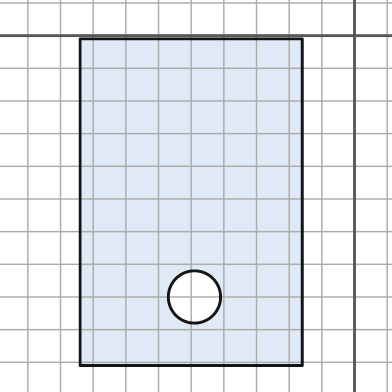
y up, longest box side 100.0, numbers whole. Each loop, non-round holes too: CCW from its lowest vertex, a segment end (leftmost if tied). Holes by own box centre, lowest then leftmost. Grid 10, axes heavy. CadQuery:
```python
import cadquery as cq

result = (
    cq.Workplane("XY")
    .moveTo(-84.0, -101.0)
    .lineTo(-16.0, -101.0)
    .lineTo(-16.0, -1.0)
    .lineTo(-84.0, -1.0)
    .close()
    .moveTo(-49.0, -80.0)
    .circle(8.0)
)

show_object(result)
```